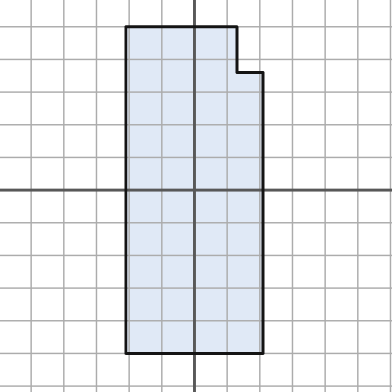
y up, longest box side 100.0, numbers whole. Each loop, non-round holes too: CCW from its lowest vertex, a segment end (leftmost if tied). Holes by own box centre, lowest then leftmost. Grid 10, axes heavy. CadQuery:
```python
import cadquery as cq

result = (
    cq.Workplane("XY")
    .moveTo(-21.0, -50.0)
    .lineTo(21.0, -50.0)
    .lineTo(21.0, 36.0)
    .lineTo(13.0, 36.0)
    .lineTo(13.0, 50.0)
    .lineTo(-21.0, 50.0)
    .close()
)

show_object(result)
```